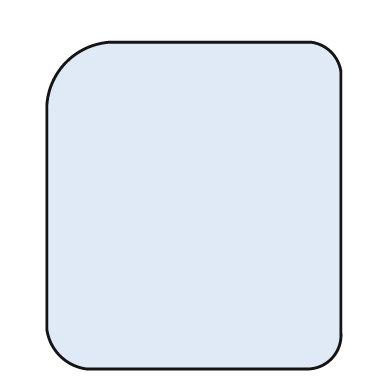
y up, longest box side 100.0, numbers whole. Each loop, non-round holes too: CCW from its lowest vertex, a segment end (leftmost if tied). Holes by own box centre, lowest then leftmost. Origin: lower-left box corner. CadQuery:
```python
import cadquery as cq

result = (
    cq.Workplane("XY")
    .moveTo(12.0, 0.0)
    .lineTo(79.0, 0.0)
    .threePointArc((87.0, 3.0), (90.0, 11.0))
    .lineTo(90.0, 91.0)
    .threePointArc((87.0, 97.0), (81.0, 100.0))
    .lineTo(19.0, 100.0)
    .threePointArc((6.0, 94.0), (0.0, 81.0))
    .lineTo(0.0, 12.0)
    .threePointArc((4.0, 4.0), (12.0, 0.0))
    .close()
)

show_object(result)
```